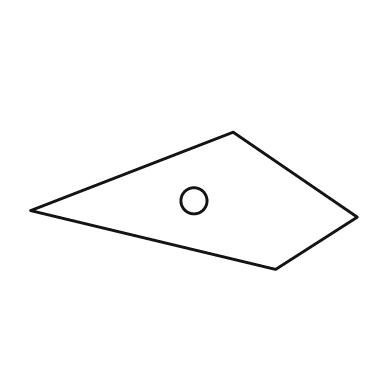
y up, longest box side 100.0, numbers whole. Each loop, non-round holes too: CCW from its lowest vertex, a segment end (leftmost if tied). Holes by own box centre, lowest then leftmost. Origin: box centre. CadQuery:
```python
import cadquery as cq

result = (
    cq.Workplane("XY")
    .moveTo(25.0, -21.0)
    .lineTo(50.0, -5.0)
    .lineTo(12.0, 21.0)
    .lineTo(-50.0, -3.0)
    .close()
    .moveTo(0.0, 0.0)
    .circle(4.0)
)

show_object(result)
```